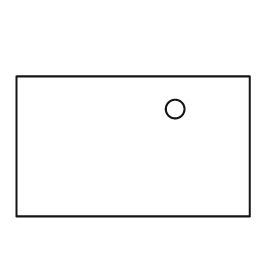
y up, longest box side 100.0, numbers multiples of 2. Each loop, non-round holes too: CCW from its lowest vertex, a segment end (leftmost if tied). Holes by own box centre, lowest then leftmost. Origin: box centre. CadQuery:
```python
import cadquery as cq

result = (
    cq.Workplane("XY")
    .moveTo(-50.0, -30.0)
    .lineTo(50.0, -30.0)
    .lineTo(50.0, 30.0)
    .lineTo(-50.0, 30.0)
    .close()
    .moveTo(18.0, 16.0)
    .circle(4.0)
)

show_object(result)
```